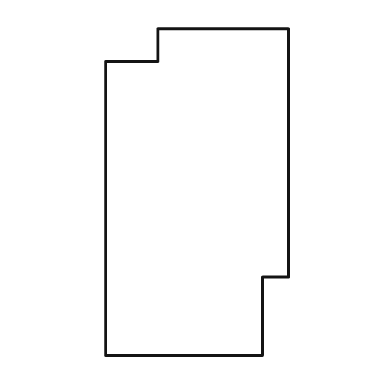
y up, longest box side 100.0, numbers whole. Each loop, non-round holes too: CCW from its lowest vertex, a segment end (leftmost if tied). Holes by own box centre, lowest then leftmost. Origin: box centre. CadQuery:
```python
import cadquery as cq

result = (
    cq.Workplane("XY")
    .moveTo(-28.0, -50.0)
    .lineTo(20.0, -50.0)
    .lineTo(20.0, -26.0)
    .lineTo(28.0, -26.0)
    .lineTo(28.0, 50.0)
    .lineTo(-12.0, 50.0)
    .lineTo(-12.0, 40.0)
    .lineTo(-28.0, 40.0)
    .close()
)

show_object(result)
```